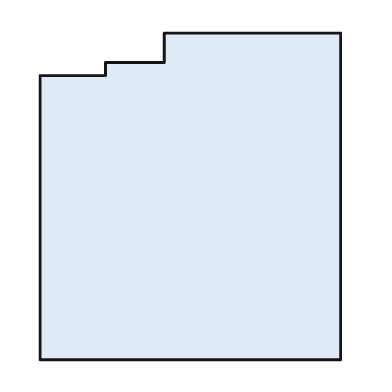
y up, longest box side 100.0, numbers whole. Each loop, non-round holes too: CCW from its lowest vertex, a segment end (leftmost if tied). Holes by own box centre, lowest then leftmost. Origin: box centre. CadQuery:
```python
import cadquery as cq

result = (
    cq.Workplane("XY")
    .moveTo(-46.0, -50.0)
    .lineTo(46.0, -50.0)
    .lineTo(46.0, 50.0)
    .lineTo(-8.0, 50.0)
    .lineTo(-8.0, 41.0)
    .lineTo(-26.0, 41.0)
    .lineTo(-26.0, 37.0)
    .lineTo(-46.0, 37.0)
    .close()
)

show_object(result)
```